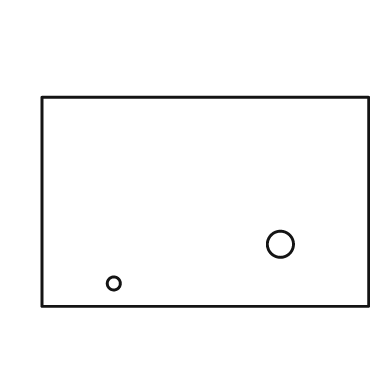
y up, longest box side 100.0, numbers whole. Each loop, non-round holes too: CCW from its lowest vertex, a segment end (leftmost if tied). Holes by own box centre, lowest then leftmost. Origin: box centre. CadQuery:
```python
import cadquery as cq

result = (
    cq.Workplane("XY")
    .moveTo(-50.0, -32.0)
    .lineTo(50.0, -32.0)
    .lineTo(50.0, 32.0)
    .lineTo(-50.0, 32.0)
    .close()
    .moveTo(-28.0, -25.0)
    .circle(2.0)
    .moveTo(23.0, -13.0)
    .circle(4.0)
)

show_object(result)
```